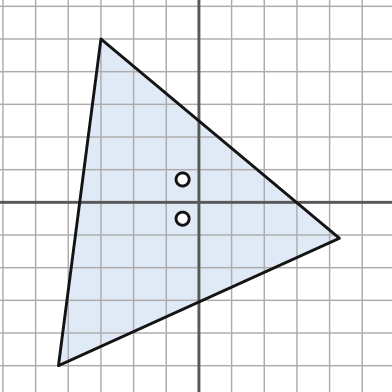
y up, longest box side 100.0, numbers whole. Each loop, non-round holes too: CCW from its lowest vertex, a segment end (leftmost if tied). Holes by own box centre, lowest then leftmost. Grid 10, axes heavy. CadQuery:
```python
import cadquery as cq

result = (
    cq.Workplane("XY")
    .moveTo(-43.0, -50.0)
    .lineTo(43.0, -11.0)
    .lineTo(-30.0, 50.0)
    .close()
    .moveTo(-5.0, -5.0)
    .circle(2.0)
    .moveTo(-5.0, 7.0)
    .circle(2.0)
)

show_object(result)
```